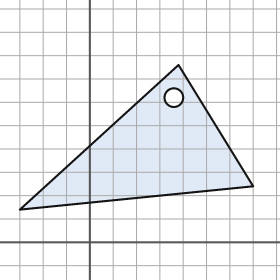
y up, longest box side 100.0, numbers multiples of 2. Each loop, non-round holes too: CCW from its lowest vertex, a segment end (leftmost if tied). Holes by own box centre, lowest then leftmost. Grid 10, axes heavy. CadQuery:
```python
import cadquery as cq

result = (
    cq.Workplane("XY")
    .moveTo(-30.0, 14.0)
    .lineTo(70.0, 24.0)
    .lineTo(38.0, 76.0)
    .close()
    .moveTo(36.0, 62.0)
    .circle(4.0)
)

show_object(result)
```